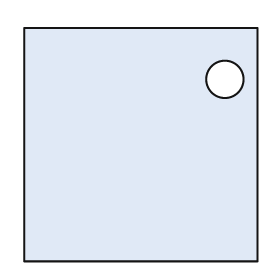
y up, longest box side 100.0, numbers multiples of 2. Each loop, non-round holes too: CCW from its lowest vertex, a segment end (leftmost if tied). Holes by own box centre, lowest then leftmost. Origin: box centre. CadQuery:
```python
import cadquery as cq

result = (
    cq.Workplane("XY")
    .moveTo(-50.0, -50.0)
    .lineTo(50.0, -50.0)
    .lineTo(50.0, 50.0)
    .lineTo(-50.0, 50.0)
    .close()
    .moveTo(36.0, 28.0)
    .circle(8.0)
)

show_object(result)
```